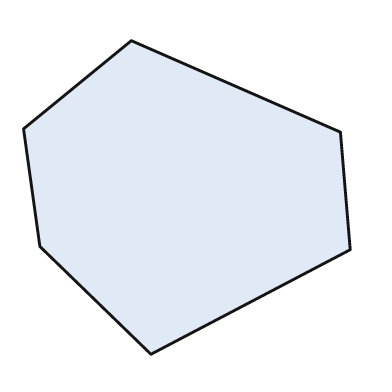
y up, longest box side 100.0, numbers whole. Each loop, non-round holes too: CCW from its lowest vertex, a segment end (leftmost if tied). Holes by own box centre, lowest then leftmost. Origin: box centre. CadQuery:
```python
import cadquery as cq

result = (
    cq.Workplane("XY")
    .moveTo(-11.0, -48.0)
    .lineTo(50.0, -16.0)
    .lineTo(47.0, 20.0)
    .lineTo(-17.0, 48.0)
    .lineTo(-50.0, 21.0)
    .lineTo(-45.0, -15.0)
    .close()
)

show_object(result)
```